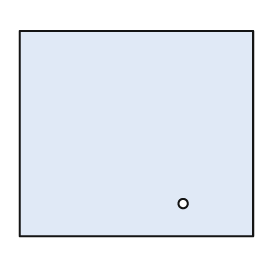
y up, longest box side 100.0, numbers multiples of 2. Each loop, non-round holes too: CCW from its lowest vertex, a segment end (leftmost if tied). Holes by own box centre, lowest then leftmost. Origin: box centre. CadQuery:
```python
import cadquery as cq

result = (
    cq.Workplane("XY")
    .moveTo(-50.0, -44.0)
    .lineTo(50.0, -44.0)
    .lineTo(50.0, 44.0)
    .lineTo(-50.0, 44.0)
    .close()
    .moveTo(20.0, -30.0)
    .circle(2.0)
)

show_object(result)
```